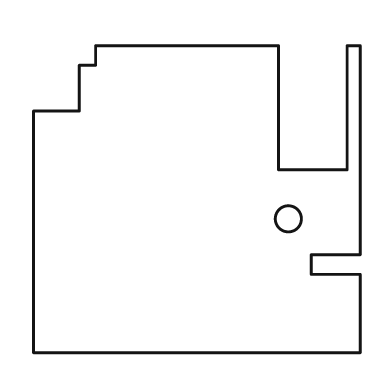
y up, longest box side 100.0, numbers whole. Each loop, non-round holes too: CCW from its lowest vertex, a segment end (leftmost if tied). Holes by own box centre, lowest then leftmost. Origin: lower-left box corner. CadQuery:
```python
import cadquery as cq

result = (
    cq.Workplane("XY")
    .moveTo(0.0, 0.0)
    .lineTo(100.0, 0.0)
    .lineTo(100.0, 24.0)
    .lineTo(85.0, 24.0)
    .lineTo(85.0, 30.0)
    .lineTo(100.0, 30.0)
    .lineTo(100.0, 94.0)
    .lineTo(96.0, 94.0)
    .lineTo(96.0, 56.0)
    .lineTo(75.0, 56.0)
    .lineTo(75.0, 94.0)
    .lineTo(19.0, 94.0)
    .lineTo(19.0, 88.0)
    .lineTo(14.0, 88.0)
    .lineTo(14.0, 74.0)
    .lineTo(0.0, 74.0)
    .close()
    .moveTo(78.0, 41.0)
    .circle(4.0)
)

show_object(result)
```